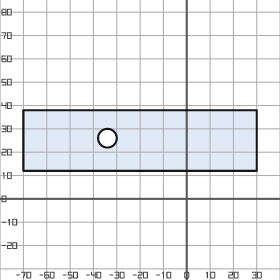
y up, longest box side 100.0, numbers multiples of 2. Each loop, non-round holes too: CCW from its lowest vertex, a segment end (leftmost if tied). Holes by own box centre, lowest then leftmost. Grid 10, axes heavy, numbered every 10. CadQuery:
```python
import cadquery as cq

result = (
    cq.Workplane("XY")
    .moveTo(-70.0, 12.0)
    .lineTo(30.0, 12.0)
    .lineTo(30.0, 38.0)
    .lineTo(-70.0, 38.0)
    .close()
    .moveTo(-34.0, 26.0)
    .circle(4.0)
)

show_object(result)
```